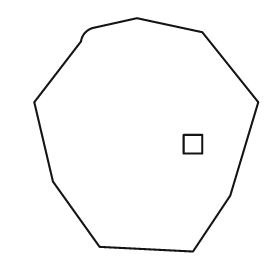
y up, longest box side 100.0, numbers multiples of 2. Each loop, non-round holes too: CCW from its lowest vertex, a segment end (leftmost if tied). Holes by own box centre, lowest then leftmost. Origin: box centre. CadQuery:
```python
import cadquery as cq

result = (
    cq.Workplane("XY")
    .moveTo(20.0, -50.0)
    .lineTo(36.0, -26.0)
    .lineTo(48.0, 14.0)
    .lineTo(24.0, 44.0)
    .lineTo(-4.0, 50.0)
    .lineTo(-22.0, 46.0)
    .threePointArc((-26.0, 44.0), (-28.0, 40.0))
    .lineTo(-48.0, 14.0)
    .lineTo(-40.0, -20.0)
    .lineTo(-20.0, -48.0)
    .close()
    .moveTo(16.0, -8.0)
    .lineTo(24.0, -8.0)
    .lineTo(24.0, 0.0)
    .lineTo(16.0, 0.0)
    .close()
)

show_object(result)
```